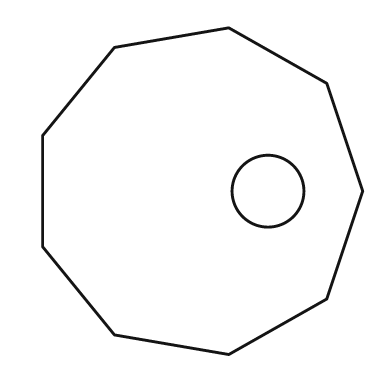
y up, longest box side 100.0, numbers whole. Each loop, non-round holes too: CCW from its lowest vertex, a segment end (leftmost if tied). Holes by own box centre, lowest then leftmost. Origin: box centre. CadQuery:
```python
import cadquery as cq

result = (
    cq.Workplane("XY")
    .moveTo(8.0, -50.0)
    .lineTo(38.0, -33.0)
    .lineTo(49.0, 0.0)
    .lineTo(38.0, 33.0)
    .lineTo(8.0, 50.0)
    .lineTo(-27.0, 44.0)
    .lineTo(-49.0, 17.0)
    .lineTo(-49.0, -17.0)
    .lineTo(-27.0, -44.0)
    .close()
    .moveTo(20.0, 0.0)
    .circle(11.0)
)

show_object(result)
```